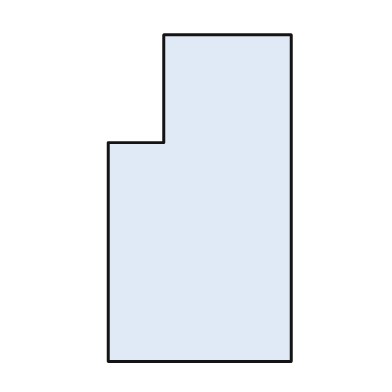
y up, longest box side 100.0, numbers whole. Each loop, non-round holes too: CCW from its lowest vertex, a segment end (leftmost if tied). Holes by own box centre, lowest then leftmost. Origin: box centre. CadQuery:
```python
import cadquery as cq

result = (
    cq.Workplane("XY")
    .moveTo(-28.0, -50.0)
    .lineTo(28.0, -50.0)
    .lineTo(28.0, 50.0)
    .lineTo(-11.0, 50.0)
    .lineTo(-11.0, 17.0)
    .lineTo(-28.0, 17.0)
    .close()
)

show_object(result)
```